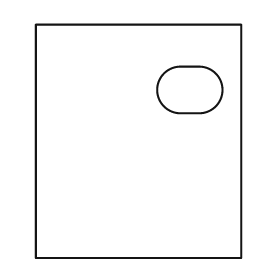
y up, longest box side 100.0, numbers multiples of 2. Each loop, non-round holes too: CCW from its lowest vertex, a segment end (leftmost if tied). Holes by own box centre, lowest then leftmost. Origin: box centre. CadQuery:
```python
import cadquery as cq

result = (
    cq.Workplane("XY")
    .moveTo(-44.0, -50.0)
    .lineTo(44.0, -50.0)
    .lineTo(44.0, 50.0)
    .lineTo(-44.0, 50.0)
    .close()
    .moveTo(18.0, 12.0)
    .lineTo(26.0, 12.0)
    .threePointArc((36.0, 22.0), (26.0, 32.0))
    .lineTo(18.0, 32.0)
    .threePointArc((8.0, 22.0), (18.0, 12.0))
    .close()
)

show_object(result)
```